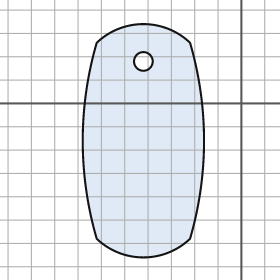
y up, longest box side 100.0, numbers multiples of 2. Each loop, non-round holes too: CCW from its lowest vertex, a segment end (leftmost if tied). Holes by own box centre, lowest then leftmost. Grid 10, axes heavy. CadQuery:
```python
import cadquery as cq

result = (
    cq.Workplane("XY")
    .moveTo(-62.0, -58.0)
    .threePointArc((-42.0, -66.0), (-22.0, -58.0))
    .threePointArc((-16.0, -16.0), (-22.0, 26.0))
    .threePointArc((-42.0, 34.0), (-62.0, 26.0))
    .threePointArc((-68.0, -16.0), (-62.0, -58.0))
    .close()
    .moveTo(-42.0, 18.0)
    .circle(4.0)
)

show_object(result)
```